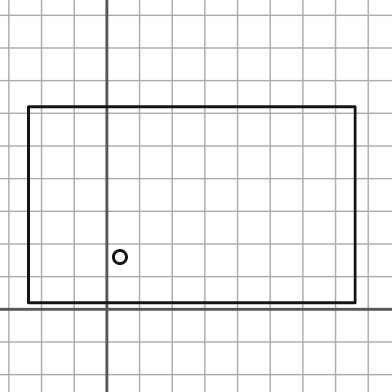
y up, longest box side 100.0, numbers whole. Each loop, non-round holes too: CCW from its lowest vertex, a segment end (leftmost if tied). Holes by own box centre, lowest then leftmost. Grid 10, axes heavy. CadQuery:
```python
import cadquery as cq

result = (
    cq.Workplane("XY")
    .moveTo(-24.0, 2.0)
    .lineTo(76.0, 2.0)
    .lineTo(76.0, 62.0)
    .lineTo(-24.0, 62.0)
    .close()
    .moveTo(4.0, 16.0)
    .circle(2.0)
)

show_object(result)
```